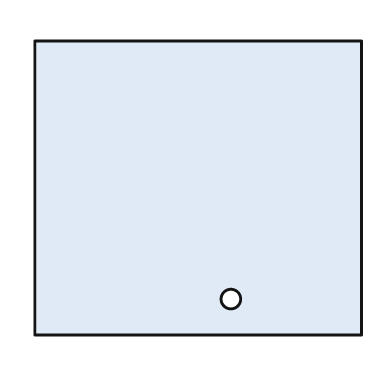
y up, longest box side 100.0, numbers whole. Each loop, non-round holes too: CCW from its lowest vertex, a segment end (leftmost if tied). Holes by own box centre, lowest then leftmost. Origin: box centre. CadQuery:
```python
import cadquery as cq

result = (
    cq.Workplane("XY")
    .moveTo(-50.0, -45.0)
    .lineTo(50.0, -45.0)
    .lineTo(50.0, 45.0)
    .lineTo(-50.0, 45.0)
    .close()
    .moveTo(10.0, -34.0)
    .circle(3.0)
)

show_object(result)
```